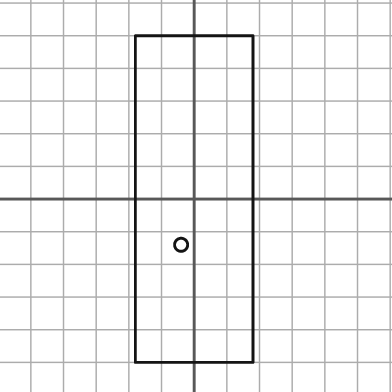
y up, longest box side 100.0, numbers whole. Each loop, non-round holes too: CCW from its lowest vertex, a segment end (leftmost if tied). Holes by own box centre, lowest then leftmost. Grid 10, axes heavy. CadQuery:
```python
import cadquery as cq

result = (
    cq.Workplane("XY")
    .moveTo(-18.0, -50.0)
    .lineTo(18.0, -50.0)
    .lineTo(18.0, 50.0)
    .lineTo(-18.0, 50.0)
    .close()
    .moveTo(-4.0, -14.0)
    .circle(2.0)
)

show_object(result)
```